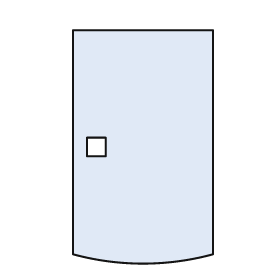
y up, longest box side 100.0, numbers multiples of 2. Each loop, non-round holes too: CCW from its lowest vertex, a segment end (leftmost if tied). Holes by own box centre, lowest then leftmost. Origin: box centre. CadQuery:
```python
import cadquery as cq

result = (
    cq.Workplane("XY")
    .moveTo(-30.0, -46.0)
    .threePointArc((0.0, -50.0), (30.0, -46.0))
    .lineTo(30.0, 50.0)
    .lineTo(-30.0, 50.0)
    .close()
    .moveTo(-24.0, -4.0)
    .lineTo(-16.0, -4.0)
    .lineTo(-16.0, 4.0)
    .lineTo(-24.0, 4.0)
    .close()
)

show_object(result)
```